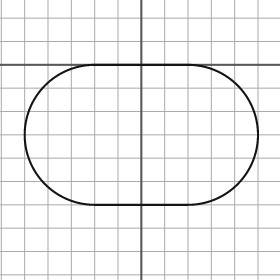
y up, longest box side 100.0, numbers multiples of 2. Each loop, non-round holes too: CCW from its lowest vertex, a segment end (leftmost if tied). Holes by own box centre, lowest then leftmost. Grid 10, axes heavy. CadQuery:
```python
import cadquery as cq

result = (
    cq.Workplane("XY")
    .moveTo(-20.0, -60.0)
    .lineTo(20.0, -60.0)
    .threePointArc((50.0, -30.0), (20.0, 0.0))
    .lineTo(-20.0, 0.0)
    .threePointArc((-50.0, -30.0), (-20.0, -60.0))
    .close()
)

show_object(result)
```